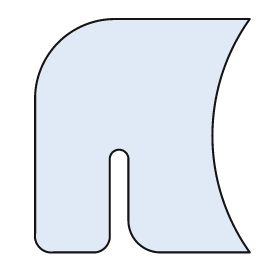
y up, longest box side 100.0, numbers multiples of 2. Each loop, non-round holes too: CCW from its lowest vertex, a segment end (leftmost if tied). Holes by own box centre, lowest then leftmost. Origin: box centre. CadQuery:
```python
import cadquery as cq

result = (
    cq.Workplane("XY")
    .moveTo(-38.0, -50.0)
    .lineTo(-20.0, -50.0)
    .threePointArc((-16.0, -48.0), (-14.0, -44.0))
    .lineTo(-14.0, -10.0)
    .threePointArc((-10.0, -6.0), (-6.0, -10.0))
    .lineTo(-6.0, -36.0)
    .threePointArc((-2.0, -46.0), (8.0, -50.0))
    .lineTo(46.0, -50.0)
    .threePointArc((30.0, 0.0), (46.0, 50.0))
    .lineTo(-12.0, 50.0)
    .threePointArc((-36.0, 40.0), (-46.0, 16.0))
    .lineTo(-46.0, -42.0)
    .threePointArc((-44.0, -48.0), (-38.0, -50.0))
    .close()
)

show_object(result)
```